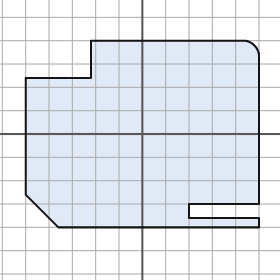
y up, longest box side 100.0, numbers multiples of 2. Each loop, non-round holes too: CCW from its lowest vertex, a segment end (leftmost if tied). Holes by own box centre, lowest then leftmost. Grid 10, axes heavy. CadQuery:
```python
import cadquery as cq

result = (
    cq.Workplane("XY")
    .moveTo(-36.0, -40.0)
    .lineTo(50.0, -40.0)
    .lineTo(50.0, -36.0)
    .lineTo(20.0, -36.0)
    .lineTo(20.0, -30.0)
    .lineTo(50.0, -30.0)
    .lineTo(50.0, 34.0)
    .threePointArc((48.0, 38.0), (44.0, 40.0))
    .lineTo(-22.0, 40.0)
    .lineTo(-22.0, 24.0)
    .lineTo(-50.0, 24.0)
    .lineTo(-50.0, -26.0)
    .close()
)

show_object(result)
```